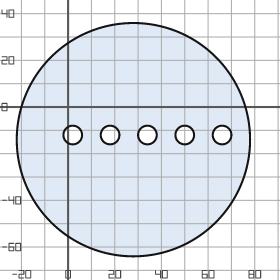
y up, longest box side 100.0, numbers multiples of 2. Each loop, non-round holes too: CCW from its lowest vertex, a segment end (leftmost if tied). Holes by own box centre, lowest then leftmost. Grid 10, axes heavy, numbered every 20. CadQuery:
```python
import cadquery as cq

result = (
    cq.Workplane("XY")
    .moveTo(28.0, -14.0)
    .circle(50.0)
    .moveTo(2.0, -12.0)
    .circle(4.0)
    .moveTo(18.0, -12.0)
    .circle(4.0)
    .moveTo(34.0, -12.0)
    .circle(4.0)
    .moveTo(50.0, -12.0)
    .circle(4.0)
    .moveTo(66.0, -12.0)
    .circle(4.0)
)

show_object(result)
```